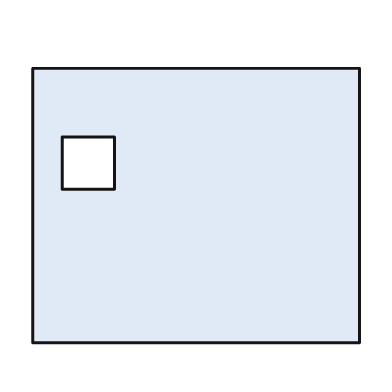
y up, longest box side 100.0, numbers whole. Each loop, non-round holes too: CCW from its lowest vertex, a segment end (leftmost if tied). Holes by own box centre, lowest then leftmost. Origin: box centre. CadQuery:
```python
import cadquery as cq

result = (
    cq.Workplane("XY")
    .moveTo(-50.0, -42.0)
    .lineTo(50.0, -42.0)
    .lineTo(50.0, 42.0)
    .lineTo(-50.0, 42.0)
    .close()
    .moveTo(-41.0, 5.0)
    .lineTo(-25.0, 5.0)
    .lineTo(-25.0, 21.0)
    .lineTo(-41.0, 21.0)
    .close()
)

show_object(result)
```